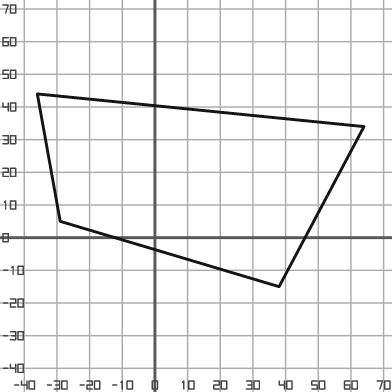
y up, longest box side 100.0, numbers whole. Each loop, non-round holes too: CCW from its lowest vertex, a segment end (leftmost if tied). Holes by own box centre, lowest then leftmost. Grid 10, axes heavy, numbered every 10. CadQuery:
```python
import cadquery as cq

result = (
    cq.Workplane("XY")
    .moveTo(38.0, -15.0)
    .lineTo(64.0, 34.0)
    .lineTo(-36.0, 44.0)
    .lineTo(-29.0, 5.0)
    .close()
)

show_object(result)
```